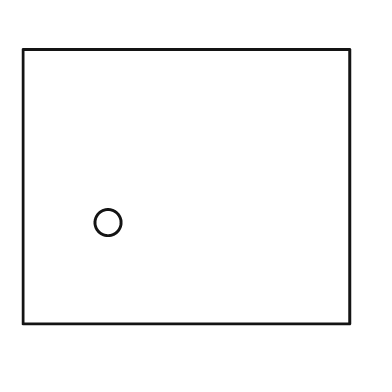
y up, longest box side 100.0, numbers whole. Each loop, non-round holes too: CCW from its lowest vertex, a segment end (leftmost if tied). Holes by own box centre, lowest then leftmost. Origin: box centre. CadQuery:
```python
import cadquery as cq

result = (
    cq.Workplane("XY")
    .moveTo(-50.0, -42.0)
    .lineTo(50.0, -42.0)
    .lineTo(50.0, 42.0)
    .lineTo(-50.0, 42.0)
    .close()
    .moveTo(-24.0, -11.0)
    .circle(4.0)
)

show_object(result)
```